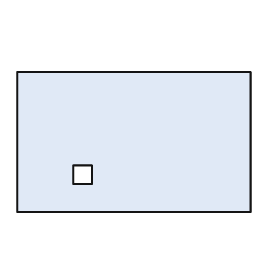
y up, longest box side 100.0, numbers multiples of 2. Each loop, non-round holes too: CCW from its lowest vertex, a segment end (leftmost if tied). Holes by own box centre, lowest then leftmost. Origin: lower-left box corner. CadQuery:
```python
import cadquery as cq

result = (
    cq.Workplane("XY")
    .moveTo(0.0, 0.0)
    .lineTo(100.0, 0.0)
    .lineTo(100.0, 60.0)
    .lineTo(0.0, 60.0)
    .close()
    .moveTo(24.0, 12.0)
    .lineTo(32.0, 12.0)
    .lineTo(32.0, 20.0)
    .lineTo(24.0, 20.0)
    .close()
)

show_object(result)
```